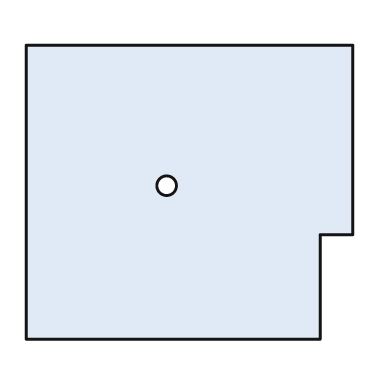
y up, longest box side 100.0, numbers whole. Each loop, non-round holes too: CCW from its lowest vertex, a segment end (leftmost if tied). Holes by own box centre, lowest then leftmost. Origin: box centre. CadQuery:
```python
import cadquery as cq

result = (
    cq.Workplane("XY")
    .moveTo(-50.0, -45.0)
    .lineTo(40.0, -45.0)
    .lineTo(40.0, -13.0)
    .lineTo(50.0, -13.0)
    .lineTo(50.0, 45.0)
    .lineTo(-50.0, 45.0)
    .close()
    .moveTo(-7.0, 2.0)
    .circle(3.0)
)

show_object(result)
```